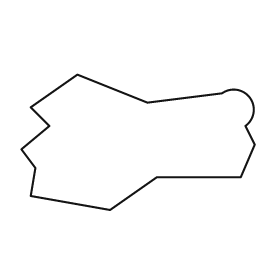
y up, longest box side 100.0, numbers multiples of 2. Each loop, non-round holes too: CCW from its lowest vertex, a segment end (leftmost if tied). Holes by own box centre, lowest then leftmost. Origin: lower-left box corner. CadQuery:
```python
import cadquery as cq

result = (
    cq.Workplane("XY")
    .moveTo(38.0, 0.0)
    .lineTo(58.0, 14.0)
    .lineTo(94.0, 14.0)
    .lineTo(100.0, 28.0)
    .lineTo(96.0, 36.0)
    .threePointArc((98.0, 48.0), (86.0, 50.0))
    .lineTo(54.0, 46.0)
    .lineTo(24.0, 58.0)
    .lineTo(4.0, 44.0)
    .lineTo(12.0, 36.0)
    .lineTo(0.0, 26.0)
    .lineTo(6.0, 18.0)
    .lineTo(4.0, 6.0)
    .close()
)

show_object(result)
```